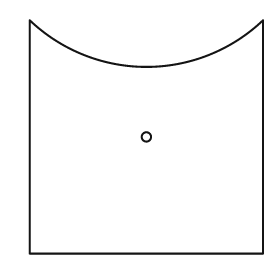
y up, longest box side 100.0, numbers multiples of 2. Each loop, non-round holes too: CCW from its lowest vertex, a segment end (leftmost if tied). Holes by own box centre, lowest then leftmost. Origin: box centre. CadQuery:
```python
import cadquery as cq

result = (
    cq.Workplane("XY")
    .moveTo(-50.0, -50.0)
    .lineTo(50.0, -50.0)
    .lineTo(50.0, 50.0)
    .threePointArc((0.0, 30.0), (-50.0, 50.0))
    .close()
    .moveTo(0.0, 0.0)
    .circle(2.0)
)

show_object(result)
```